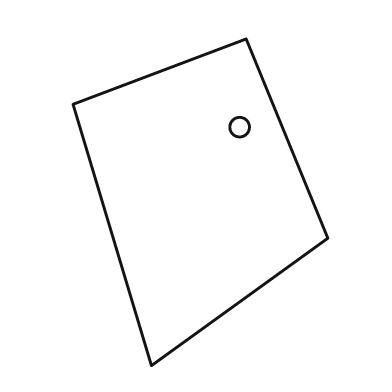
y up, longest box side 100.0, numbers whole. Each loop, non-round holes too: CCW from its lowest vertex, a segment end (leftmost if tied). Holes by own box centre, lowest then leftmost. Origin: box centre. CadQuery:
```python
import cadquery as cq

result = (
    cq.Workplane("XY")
    .moveTo(-15.0, -50.0)
    .lineTo(39.0, -11.0)
    .lineTo(14.0, 50.0)
    .lineTo(-39.0, 30.0)
    .close()
    .moveTo(12.0, 23.0)
    .circle(3.0)
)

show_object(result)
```